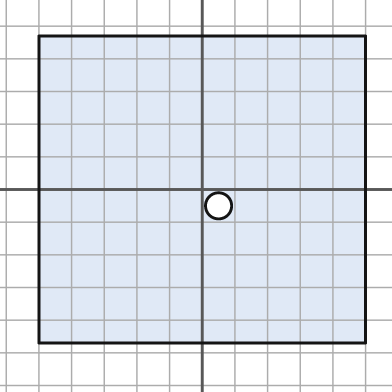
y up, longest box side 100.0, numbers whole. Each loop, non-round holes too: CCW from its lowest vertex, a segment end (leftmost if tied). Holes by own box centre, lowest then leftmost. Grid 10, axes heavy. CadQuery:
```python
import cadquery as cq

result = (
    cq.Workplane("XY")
    .moveTo(-50.0, -47.0)
    .lineTo(50.0, -47.0)
    .lineTo(50.0, 47.0)
    .lineTo(-50.0, 47.0)
    .close()
    .moveTo(5.0, -5.0)
    .circle(4.0)
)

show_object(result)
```